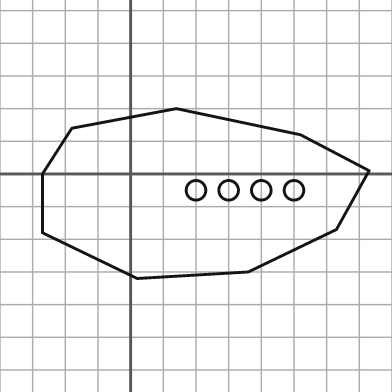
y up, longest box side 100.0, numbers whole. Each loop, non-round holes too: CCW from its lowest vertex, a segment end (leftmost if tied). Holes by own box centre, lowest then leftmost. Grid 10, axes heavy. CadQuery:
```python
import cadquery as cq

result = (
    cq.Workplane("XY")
    .moveTo(2.0, -32.0)
    .lineTo(36.0, -30.0)
    .lineTo(63.0, -17.0)
    .lineTo(73.0, 1.0)
    .lineTo(52.0, 12.0)
    .lineTo(14.0, 20.0)
    .lineTo(-18.0, 14.0)
    .lineTo(-27.0, 0.0)
    .lineTo(-27.0, -18.0)
    .close()
    .moveTo(20.0, -5.0)
    .circle(3.0)
    .moveTo(30.0, -5.0)
    .circle(3.0)
    .moveTo(40.0, -5.0)
    .circle(3.0)
    .moveTo(50.0, -5.0)
    .circle(3.0)
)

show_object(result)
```